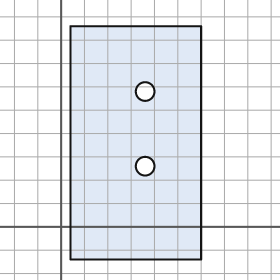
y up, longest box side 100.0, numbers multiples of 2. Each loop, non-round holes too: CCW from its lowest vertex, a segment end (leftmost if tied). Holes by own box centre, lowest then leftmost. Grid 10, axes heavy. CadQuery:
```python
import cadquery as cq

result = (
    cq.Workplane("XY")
    .moveTo(4.0, -14.0)
    .lineTo(60.0, -14.0)
    .lineTo(60.0, 86.0)
    .lineTo(4.0, 86.0)
    .close()
    .moveTo(36.0, 26.0)
    .circle(4.0)
    .moveTo(36.0, 58.0)
    .circle(4.0)
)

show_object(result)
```